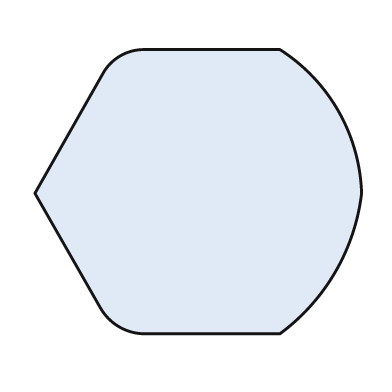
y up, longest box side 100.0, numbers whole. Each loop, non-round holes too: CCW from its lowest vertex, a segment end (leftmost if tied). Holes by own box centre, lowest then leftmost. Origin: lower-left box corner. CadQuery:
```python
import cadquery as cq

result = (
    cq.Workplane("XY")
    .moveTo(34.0, 0.0)
    .lineTo(75.0, 0.0)
    .threePointArc((92.0, 19.0), (100.0, 43.0))
    .threePointArc((93.0, 68.0), (75.0, 87.0))
    .lineTo(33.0, 87.0)
    .threePointArc((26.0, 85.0), (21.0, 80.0))
    .lineTo(0.0, 43.0)
    .lineTo(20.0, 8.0)
    .threePointArc((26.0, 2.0), (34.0, 0.0))
    .close()
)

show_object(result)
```